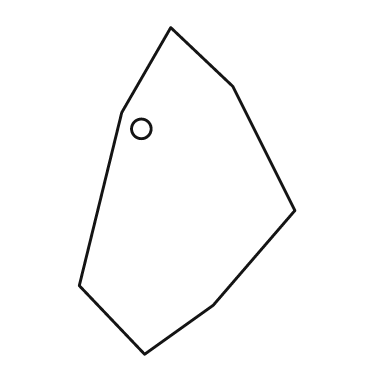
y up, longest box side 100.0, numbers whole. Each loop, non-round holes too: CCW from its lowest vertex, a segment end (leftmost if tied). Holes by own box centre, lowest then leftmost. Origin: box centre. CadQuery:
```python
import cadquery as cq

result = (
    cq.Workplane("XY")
    .moveTo(-13.0, -50.0)
    .lineTo(8.0, -35.0)
    .lineTo(33.0, -6.0)
    .lineTo(14.0, 32.0)
    .lineTo(-5.0, 50.0)
    .lineTo(-20.0, 24.0)
    .lineTo(-33.0, -29.0)
    .close()
    .moveTo(-14.0, 19.0)
    .circle(3.0)
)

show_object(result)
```